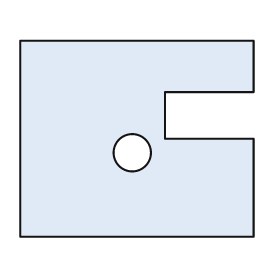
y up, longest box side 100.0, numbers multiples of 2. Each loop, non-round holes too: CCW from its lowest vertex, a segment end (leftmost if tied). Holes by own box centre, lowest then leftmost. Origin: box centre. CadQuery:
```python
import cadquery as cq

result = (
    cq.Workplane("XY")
    .moveTo(-50.0, -42.0)
    .lineTo(50.0, -42.0)
    .lineTo(50.0, 0.0)
    .lineTo(12.0, 0.0)
    .lineTo(12.0, 20.0)
    .lineTo(50.0, 20.0)
    .lineTo(50.0, 42.0)
    .lineTo(-50.0, 42.0)
    .close()
    .moveTo(-2.0, -6.0)
    .circle(8.0)
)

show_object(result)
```